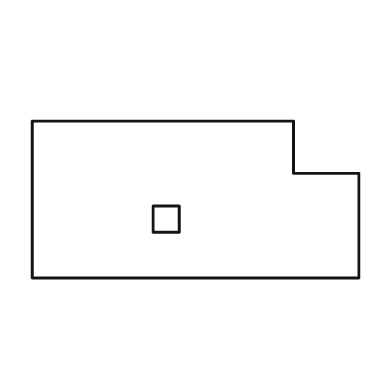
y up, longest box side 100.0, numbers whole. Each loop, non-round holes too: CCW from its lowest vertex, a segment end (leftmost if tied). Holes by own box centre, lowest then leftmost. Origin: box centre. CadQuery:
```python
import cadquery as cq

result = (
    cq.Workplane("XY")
    .moveTo(-50.0, -24.0)
    .lineTo(50.0, -24.0)
    .lineTo(50.0, 8.0)
    .lineTo(30.0, 8.0)
    .lineTo(30.0, 24.0)
    .lineTo(-50.0, 24.0)
    .close()
    .moveTo(-13.0, -10.0)
    .lineTo(-5.0, -10.0)
    .lineTo(-5.0, -2.0)
    .lineTo(-13.0, -2.0)
    .close()
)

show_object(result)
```